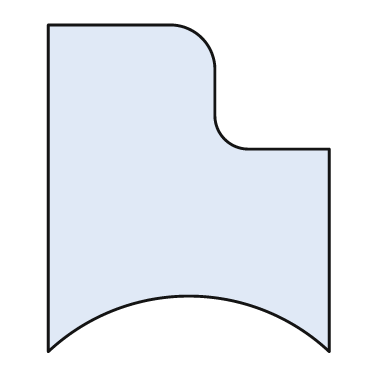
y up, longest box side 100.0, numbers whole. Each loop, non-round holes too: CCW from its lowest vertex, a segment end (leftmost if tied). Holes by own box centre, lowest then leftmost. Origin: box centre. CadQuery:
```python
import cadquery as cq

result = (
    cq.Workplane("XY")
    .moveTo(-43.0, -50.0)
    .threePointArc((0.0, -33.0), (43.0, -50.0))
    .lineTo(43.0, 12.0)
    .lineTo(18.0, 12.0)
    .threePointArc((11.0, 15.0), (8.0, 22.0))
    .lineTo(8.0, 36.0)
    .threePointArc((4.0, 46.0), (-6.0, 50.0))
    .lineTo(-43.0, 50.0)
    .close()
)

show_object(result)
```